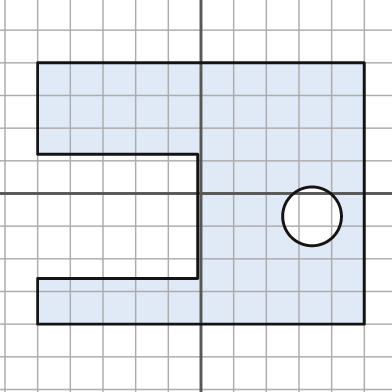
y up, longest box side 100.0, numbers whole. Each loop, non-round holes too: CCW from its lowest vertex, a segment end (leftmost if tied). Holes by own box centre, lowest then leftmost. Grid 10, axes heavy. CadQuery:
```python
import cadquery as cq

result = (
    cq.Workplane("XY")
    .moveTo(-50.0, -40.0)
    .lineTo(50.0, -40.0)
    .lineTo(50.0, 40.0)
    .lineTo(-50.0, 40.0)
    .lineTo(-50.0, 12.0)
    .lineTo(-1.0, 12.0)
    .lineTo(-1.0, -26.0)
    .lineTo(-50.0, -26.0)
    .close()
    .moveTo(34.0, -7.0)
    .circle(9.0)
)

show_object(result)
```